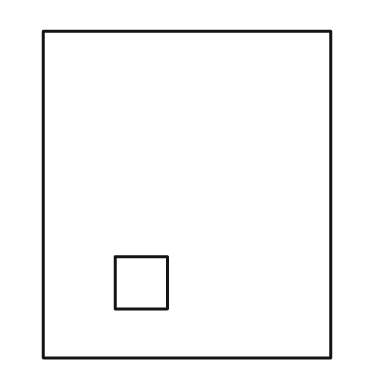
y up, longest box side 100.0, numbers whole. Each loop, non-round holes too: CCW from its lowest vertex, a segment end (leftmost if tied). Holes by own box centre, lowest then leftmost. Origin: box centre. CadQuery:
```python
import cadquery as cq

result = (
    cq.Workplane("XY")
    .moveTo(-44.0, -50.0)
    .lineTo(44.0, -50.0)
    .lineTo(44.0, 50.0)
    .lineTo(-44.0, 50.0)
    .close()
    .moveTo(-22.0, -35.0)
    .lineTo(-6.0, -35.0)
    .lineTo(-6.0, -19.0)
    .lineTo(-22.0, -19.0)
    .close()
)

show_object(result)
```